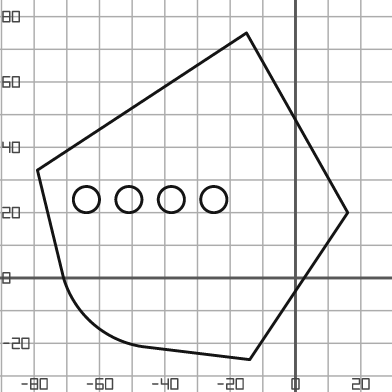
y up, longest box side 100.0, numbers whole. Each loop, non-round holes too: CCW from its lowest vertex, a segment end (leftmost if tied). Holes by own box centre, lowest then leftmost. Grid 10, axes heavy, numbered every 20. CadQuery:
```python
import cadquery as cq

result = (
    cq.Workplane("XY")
    .moveTo(-14.0, -25.0)
    .lineTo(16.0, 20.0)
    .lineTo(-15.0, 75.0)
    .lineTo(-79.0, 33.0)
    .lineTo(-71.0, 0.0)
    .threePointArc((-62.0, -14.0), (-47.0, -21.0))
    .close()
    .moveTo(-64.0, 24.0)
    .circle(4.0)
    .moveTo(-51.0, 24.0)
    .circle(4.0)
    .moveTo(-38.0, 24.0)
    .circle(4.0)
    .moveTo(-25.0, 24.0)
    .circle(4.0)
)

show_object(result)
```